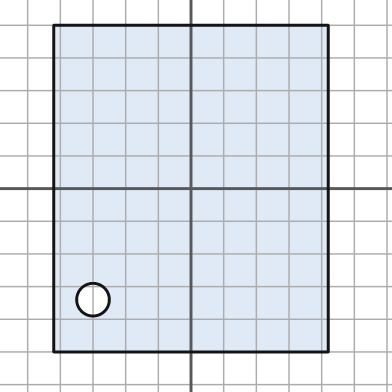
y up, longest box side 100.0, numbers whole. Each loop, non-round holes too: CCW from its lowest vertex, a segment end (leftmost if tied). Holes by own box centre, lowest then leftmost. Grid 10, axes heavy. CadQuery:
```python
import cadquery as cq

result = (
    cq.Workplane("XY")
    .moveTo(-42.0, -50.0)
    .lineTo(42.0, -50.0)
    .lineTo(42.0, 50.0)
    .lineTo(-42.0, 50.0)
    .close()
    .moveTo(-30.0, -34.0)
    .circle(5.0)
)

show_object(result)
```